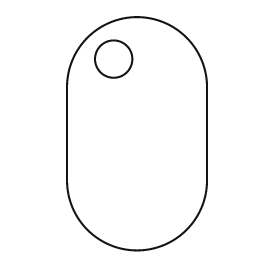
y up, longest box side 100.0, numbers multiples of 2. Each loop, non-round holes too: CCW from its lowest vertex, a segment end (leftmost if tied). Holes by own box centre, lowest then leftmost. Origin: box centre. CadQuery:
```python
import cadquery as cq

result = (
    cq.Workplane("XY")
    .moveTo(-30.0, -20.0)
    .threePointArc((0.0, -50.0), (30.0, -20.0))
    .lineTo(30.0, 20.0)
    .threePointArc((0.0, 50.0), (-30.0, 20.0))
    .close()
    .moveTo(-10.0, 32.0)
    .circle(8.0)
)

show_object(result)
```